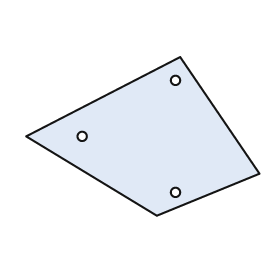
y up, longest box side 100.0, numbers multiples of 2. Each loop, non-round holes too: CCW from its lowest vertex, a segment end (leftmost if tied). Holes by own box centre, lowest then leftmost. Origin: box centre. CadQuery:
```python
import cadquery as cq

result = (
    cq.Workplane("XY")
    .moveTo(6.0, -34.0)
    .lineTo(50.0, -16.0)
    .lineTo(16.0, 34.0)
    .lineTo(-50.0, 0.0)
    .close()
    .moveTo(14.0, -24.0)
    .circle(2.0)
    .moveTo(-26.0, 0.0)
    .circle(2.0)
    .moveTo(14.0, 24.0)
    .circle(2.0)
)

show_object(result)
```